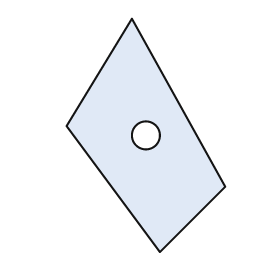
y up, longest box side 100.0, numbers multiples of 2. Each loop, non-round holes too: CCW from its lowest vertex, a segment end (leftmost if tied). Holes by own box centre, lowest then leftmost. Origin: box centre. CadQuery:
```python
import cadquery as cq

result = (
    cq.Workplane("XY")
    .moveTo(6.0, -50.0)
    .lineTo(34.0, -22.0)
    .lineTo(-6.0, 50.0)
    .lineTo(-34.0, 4.0)
    .close()
    .moveTo(0.0, 0.0)
    .circle(6.0)
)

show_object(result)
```